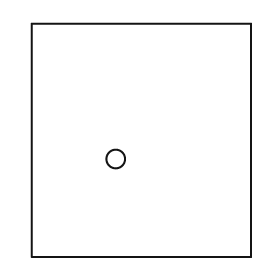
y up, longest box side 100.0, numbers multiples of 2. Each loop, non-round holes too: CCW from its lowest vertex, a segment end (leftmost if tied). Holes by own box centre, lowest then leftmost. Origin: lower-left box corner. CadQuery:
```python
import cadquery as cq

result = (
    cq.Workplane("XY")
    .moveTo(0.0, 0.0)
    .lineTo(94.0, 0.0)
    .lineTo(94.0, 100.0)
    .lineTo(0.0, 100.0)
    .close()
    .moveTo(36.0, 42.0)
    .circle(4.0)
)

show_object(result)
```